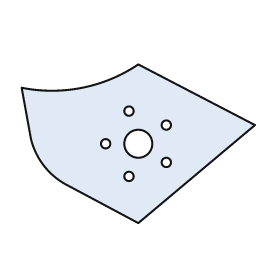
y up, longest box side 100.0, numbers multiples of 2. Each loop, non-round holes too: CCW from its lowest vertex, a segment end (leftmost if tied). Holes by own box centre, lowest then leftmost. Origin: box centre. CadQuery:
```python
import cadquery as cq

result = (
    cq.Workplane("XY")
    .moveTo(0.0, -34.0)
    .lineTo(50.0, 8.0)
    .lineTo(0.0, 34.0)
    .threePointArc((-24.0, 24.0), (-50.0, 24.0))
    .lineTo(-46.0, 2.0)
    .threePointArc((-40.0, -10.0), (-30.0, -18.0))
    .close()
    .moveTo(-4.0, -14.0)
    .circle(2.0)
    .moveTo(12.0, -8.0)
    .circle(2.0)
    .moveTo(-14.0, 0.0)
    .circle(2.0)
    .moveTo(0.0, 0.0)
    .circle(6.0)
    .moveTo(12.0, 8.0)
    .circle(2.0)
    .moveTo(-4.0, 14.0)
    .circle(2.0)
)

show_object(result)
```